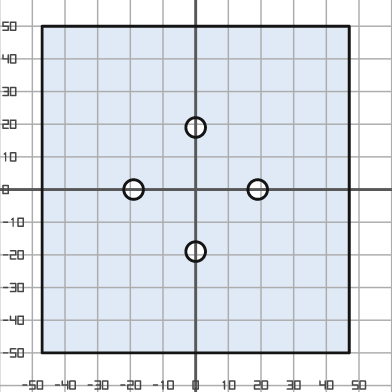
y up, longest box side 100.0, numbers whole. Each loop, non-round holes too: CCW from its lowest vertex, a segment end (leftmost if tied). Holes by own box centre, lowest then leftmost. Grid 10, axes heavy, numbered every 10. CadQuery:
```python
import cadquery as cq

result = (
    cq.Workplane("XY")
    .moveTo(-47.0, -50.0)
    .lineTo(47.0, -50.0)
    .lineTo(47.0, 50.0)
    .lineTo(-47.0, 50.0)
    .close()
    .moveTo(0.0, -19.0)
    .circle(3.0)
    .moveTo(-19.0, 0.0)
    .circle(3.0)
    .moveTo(19.0, 0.0)
    .circle(3.0)
    .moveTo(0.0, 19.0)
    .circle(3.0)
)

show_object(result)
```